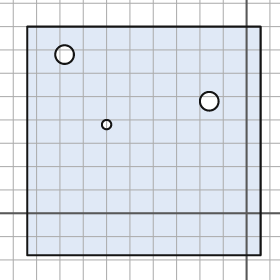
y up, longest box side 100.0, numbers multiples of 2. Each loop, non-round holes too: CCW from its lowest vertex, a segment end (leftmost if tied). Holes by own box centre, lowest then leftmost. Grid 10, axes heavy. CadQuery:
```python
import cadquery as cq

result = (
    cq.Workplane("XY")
    .moveTo(-94.0, -18.0)
    .lineTo(6.0, -18.0)
    .lineTo(6.0, 80.0)
    .lineTo(-94.0, 80.0)
    .close()
    .moveTo(-60.0, 38.0)
    .circle(2.0)
    .moveTo(-16.0, 48.0)
    .circle(4.0)
    .moveTo(-78.0, 68.0)
    .circle(4.0)
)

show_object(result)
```